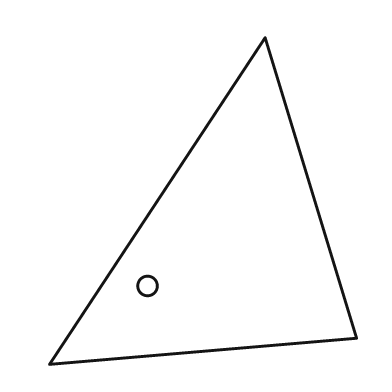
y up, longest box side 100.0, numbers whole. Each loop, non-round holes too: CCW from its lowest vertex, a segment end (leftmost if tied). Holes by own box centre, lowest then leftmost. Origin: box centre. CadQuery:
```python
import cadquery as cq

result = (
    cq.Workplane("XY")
    .moveTo(-47.0, -50.0)
    .lineTo(47.0, -42.0)
    .lineTo(19.0, 50.0)
    .close()
    .moveTo(-17.0, -26.0)
    .circle(3.0)
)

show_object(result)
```